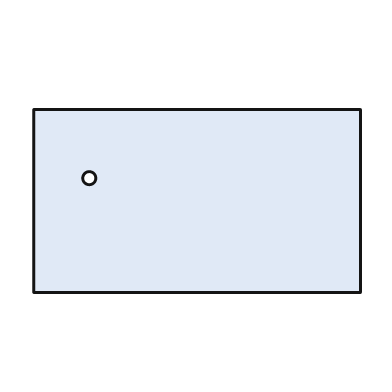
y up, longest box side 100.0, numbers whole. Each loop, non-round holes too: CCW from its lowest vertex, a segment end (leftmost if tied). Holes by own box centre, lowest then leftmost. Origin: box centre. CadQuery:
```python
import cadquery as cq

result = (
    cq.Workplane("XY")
    .moveTo(-50.0, -28.0)
    .lineTo(50.0, -28.0)
    .lineTo(50.0, 28.0)
    .lineTo(-50.0, 28.0)
    .close()
    .moveTo(-33.0, 7.0)
    .circle(2.0)
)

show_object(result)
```